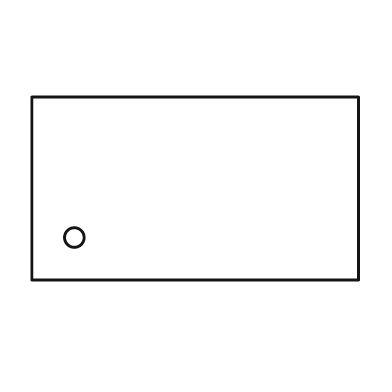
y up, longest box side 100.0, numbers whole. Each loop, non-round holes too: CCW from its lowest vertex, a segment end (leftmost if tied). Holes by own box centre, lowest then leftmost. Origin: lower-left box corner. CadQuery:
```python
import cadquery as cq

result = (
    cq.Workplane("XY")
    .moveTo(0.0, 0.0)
    .lineTo(100.0, 0.0)
    .lineTo(100.0, 56.0)
    .lineTo(0.0, 56.0)
    .close()
    .moveTo(13.0, 13.0)
    .circle(3.0)
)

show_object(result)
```